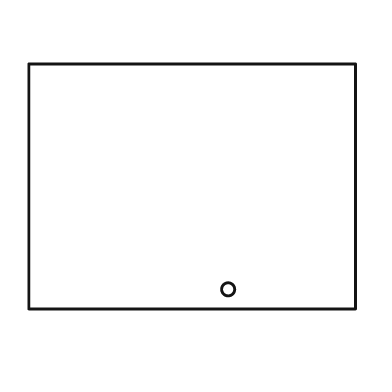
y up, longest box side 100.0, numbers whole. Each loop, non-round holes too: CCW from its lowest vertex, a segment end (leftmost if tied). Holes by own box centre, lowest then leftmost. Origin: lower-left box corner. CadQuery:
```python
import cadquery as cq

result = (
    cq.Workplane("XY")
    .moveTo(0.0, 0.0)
    .lineTo(100.0, 0.0)
    .lineTo(100.0, 75.0)
    .lineTo(0.0, 75.0)
    .close()
    .moveTo(61.0, 6.0)
    .circle(2.0)
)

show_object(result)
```